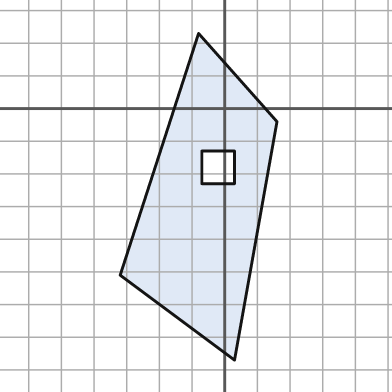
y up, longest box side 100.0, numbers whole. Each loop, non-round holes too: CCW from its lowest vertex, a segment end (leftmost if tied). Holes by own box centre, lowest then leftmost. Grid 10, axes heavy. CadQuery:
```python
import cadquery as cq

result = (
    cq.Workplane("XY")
    .moveTo(3.0, -77.0)
    .lineTo(16.0, -4.0)
    .lineTo(-8.0, 23.0)
    .lineTo(-32.0, -51.0)
    .close()
    .moveTo(-7.0, -23.0)
    .lineTo(3.0, -23.0)
    .lineTo(3.0, -13.0)
    .lineTo(-7.0, -13.0)
    .close()
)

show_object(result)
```